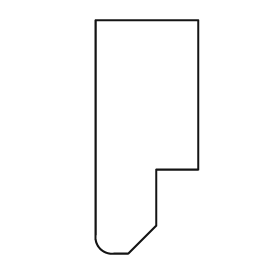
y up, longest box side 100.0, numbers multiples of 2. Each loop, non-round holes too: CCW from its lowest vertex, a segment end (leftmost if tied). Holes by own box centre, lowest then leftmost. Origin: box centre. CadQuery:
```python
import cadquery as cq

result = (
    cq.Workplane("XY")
    .moveTo(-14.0, -50.0)
    .lineTo(-8.0, -50.0)
    .lineTo(4.0, -38.0)
    .lineTo(4.0, -14.0)
    .lineTo(22.0, -14.0)
    .lineTo(22.0, 50.0)
    .lineTo(-22.0, 50.0)
    .lineTo(-22.0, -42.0)
    .threePointArc((-20.0, -48.0), (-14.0, -50.0))
    .close()
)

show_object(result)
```